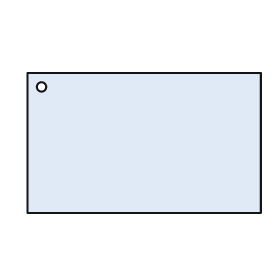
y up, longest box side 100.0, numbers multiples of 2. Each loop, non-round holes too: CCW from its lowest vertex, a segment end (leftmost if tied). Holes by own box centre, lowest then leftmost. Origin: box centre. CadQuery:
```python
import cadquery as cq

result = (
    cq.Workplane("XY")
    .moveTo(-50.0, -30.0)
    .lineTo(50.0, -30.0)
    .lineTo(50.0, 30.0)
    .lineTo(-50.0, 30.0)
    .close()
    .moveTo(-44.0, 24.0)
    .circle(2.0)
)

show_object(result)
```